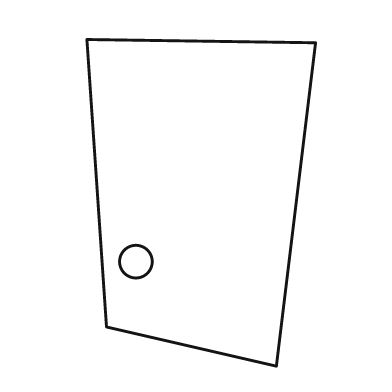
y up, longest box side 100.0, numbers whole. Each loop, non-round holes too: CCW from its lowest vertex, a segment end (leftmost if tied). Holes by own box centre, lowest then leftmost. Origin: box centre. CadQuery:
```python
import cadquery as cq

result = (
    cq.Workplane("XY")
    .moveTo(23.0, -50.0)
    .lineTo(35.0, 49.0)
    .lineTo(-35.0, 50.0)
    .lineTo(-29.0, -38.0)
    .close()
    .moveTo(-20.0, -18.0)
    .circle(5.0)
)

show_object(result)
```